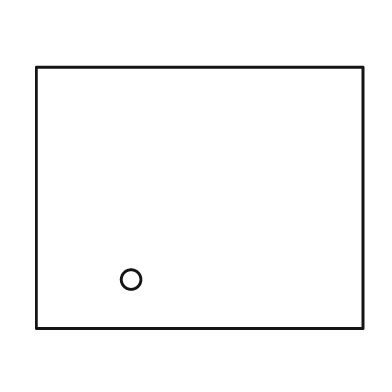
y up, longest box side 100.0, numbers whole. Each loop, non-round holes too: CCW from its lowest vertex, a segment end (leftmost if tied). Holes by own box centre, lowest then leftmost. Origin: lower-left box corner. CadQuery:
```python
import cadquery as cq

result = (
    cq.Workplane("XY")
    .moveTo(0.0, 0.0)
    .lineTo(100.0, 0.0)
    .lineTo(100.0, 80.0)
    .lineTo(0.0, 80.0)
    .close()
    .moveTo(29.0, 15.0)
    .circle(3.0)
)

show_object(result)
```